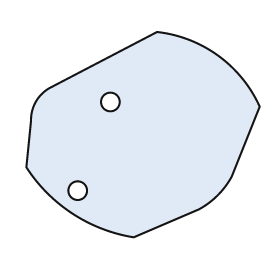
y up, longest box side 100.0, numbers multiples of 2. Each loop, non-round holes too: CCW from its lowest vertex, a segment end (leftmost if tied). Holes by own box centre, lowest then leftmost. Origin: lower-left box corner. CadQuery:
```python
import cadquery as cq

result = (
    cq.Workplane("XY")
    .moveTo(46.0, 0.0)
    .lineTo(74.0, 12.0)
    .threePointArc((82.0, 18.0), (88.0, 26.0))
    .lineTo(100.0, 56.0)
    .threePointArc((82.0, 78.0), (56.0, 88.0))
    .lineTo(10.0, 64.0)
    .threePointArc((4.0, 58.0), (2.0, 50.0))
    .lineTo(0.0, 30.0)
    .threePointArc((20.0, 10.0), (46.0, 0.0))
    .close()
    .moveTo(22.0, 20.0)
    .circle(4.0)
    .moveTo(36.0, 58.0)
    .circle(4.0)
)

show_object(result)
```